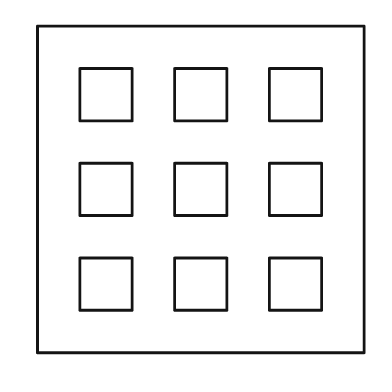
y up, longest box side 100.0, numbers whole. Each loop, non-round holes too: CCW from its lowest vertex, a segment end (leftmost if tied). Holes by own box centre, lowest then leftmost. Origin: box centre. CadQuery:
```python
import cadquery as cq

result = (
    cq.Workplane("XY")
    .moveTo(-50.0, -50.0)
    .lineTo(50.0, -50.0)
    .lineTo(50.0, 50.0)
    .lineTo(-50.0, 50.0)
    .close()
    .moveTo(-37.0, -37.0)
    .lineTo(-21.0, -37.0)
    .lineTo(-21.0, -21.0)
    .lineTo(-37.0, -21.0)
    .close()
    .moveTo(-8.0, -37.0)
    .lineTo(8.0, -37.0)
    .lineTo(8.0, -21.0)
    .lineTo(-8.0, -21.0)
    .close()
    .moveTo(21.0, -37.0)
    .lineTo(37.0, -37.0)
    .lineTo(37.0, -21.0)
    .lineTo(21.0, -21.0)
    .close()
    .moveTo(-37.0, -8.0)
    .lineTo(-21.0, -8.0)
    .lineTo(-21.0, 8.0)
    .lineTo(-37.0, 8.0)
    .close()
    .moveTo(-8.0, -8.0)
    .lineTo(8.0, -8.0)
    .lineTo(8.0, 8.0)
    .lineTo(-8.0, 8.0)
    .close()
    .moveTo(21.0, -8.0)
    .lineTo(37.0, -8.0)
    .lineTo(37.0, 8.0)
    .lineTo(21.0, 8.0)
    .close()
    .moveTo(-37.0, 21.0)
    .lineTo(-21.0, 21.0)
    .lineTo(-21.0, 37.0)
    .lineTo(-37.0, 37.0)
    .close()
    .moveTo(-8.0, 21.0)
    .lineTo(8.0, 21.0)
    .lineTo(8.0, 37.0)
    .lineTo(-8.0, 37.0)
    .close()
    .moveTo(21.0, 21.0)
    .lineTo(37.0, 21.0)
    .lineTo(37.0, 37.0)
    .lineTo(21.0, 37.0)
    .close()
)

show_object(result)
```